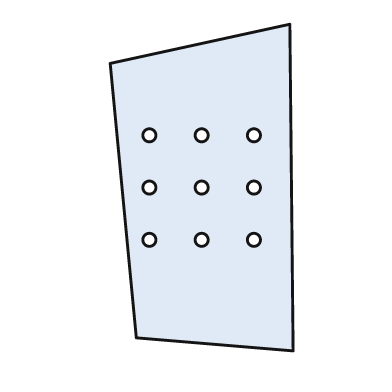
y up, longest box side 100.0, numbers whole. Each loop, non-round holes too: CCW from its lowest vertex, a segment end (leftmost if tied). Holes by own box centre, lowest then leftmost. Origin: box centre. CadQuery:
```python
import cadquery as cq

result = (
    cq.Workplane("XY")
    .moveTo(28.0, -50.0)
    .lineTo(27.0, 50.0)
    .lineTo(-28.0, 38.0)
    .lineTo(-20.0, -46.0)
    .close()
    .moveTo(-16.0, -16.0)
    .circle(2.0)
    .moveTo(0.0, -16.0)
    .circle(2.0)
    .moveTo(16.0, -16.0)
    .circle(2.0)
    .moveTo(-16.0, 0.0)
    .circle(2.0)
    .moveTo(0.0, 0.0)
    .circle(2.0)
    .moveTo(16.0, 0.0)
    .circle(2.0)
    .moveTo(-16.0, 16.0)
    .circle(2.0)
    .moveTo(0.0, 16.0)
    .circle(2.0)
    .moveTo(16.0, 16.0)
    .circle(2.0)
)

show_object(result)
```